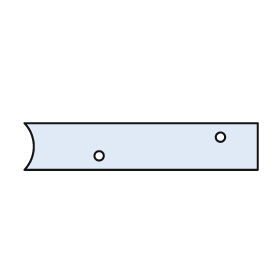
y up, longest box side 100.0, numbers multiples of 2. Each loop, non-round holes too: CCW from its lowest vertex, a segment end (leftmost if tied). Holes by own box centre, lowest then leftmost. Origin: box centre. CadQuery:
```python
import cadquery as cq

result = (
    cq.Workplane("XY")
    .moveTo(-50.0, -10.0)
    .lineTo(50.0, -10.0)
    .lineTo(50.0, 10.0)
    .lineTo(-50.0, 10.0)
    .threePointArc((-46.0, 0.0), (-50.0, -10.0))
    .close()
    .moveTo(-18.0, -4.0)
    .circle(2.0)
    .moveTo(34.0, 4.0)
    .circle(2.0)
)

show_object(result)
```